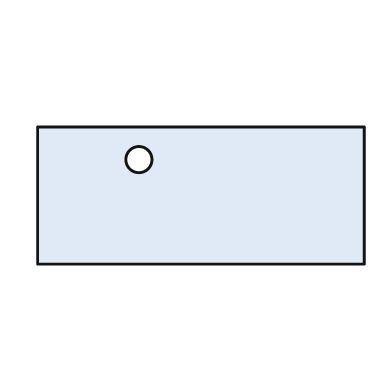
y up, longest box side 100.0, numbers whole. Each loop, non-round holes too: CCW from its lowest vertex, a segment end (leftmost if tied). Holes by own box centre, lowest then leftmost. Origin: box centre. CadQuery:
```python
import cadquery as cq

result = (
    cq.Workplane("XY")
    .moveTo(-50.0, -21.0)
    .lineTo(50.0, -21.0)
    .lineTo(50.0, 21.0)
    .lineTo(-50.0, 21.0)
    .close()
    .moveTo(-19.0, 11.0)
    .circle(4.0)
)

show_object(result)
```